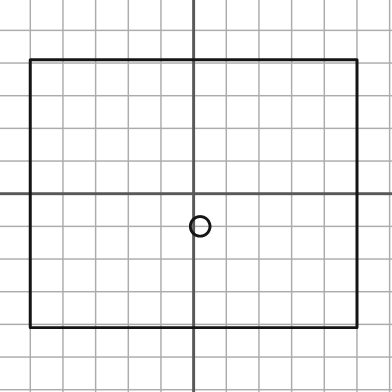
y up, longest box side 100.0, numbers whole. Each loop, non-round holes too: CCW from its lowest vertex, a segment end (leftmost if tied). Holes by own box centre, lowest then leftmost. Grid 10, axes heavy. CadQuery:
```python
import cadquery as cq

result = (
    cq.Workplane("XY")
    .moveTo(-50.0, -41.0)
    .lineTo(50.0, -41.0)
    .lineTo(50.0, 41.0)
    .lineTo(-50.0, 41.0)
    .close()
    .moveTo(2.0, -10.0)
    .circle(3.0)
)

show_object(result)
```